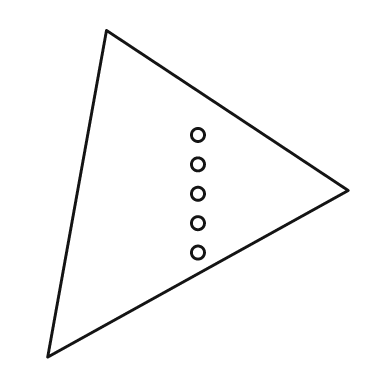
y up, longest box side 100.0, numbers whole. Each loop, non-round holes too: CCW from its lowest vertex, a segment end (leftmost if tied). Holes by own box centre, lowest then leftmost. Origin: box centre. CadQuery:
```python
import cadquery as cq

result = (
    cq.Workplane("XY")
    .moveTo(-46.0, -50.0)
    .lineTo(46.0, 1.0)
    .lineTo(-28.0, 50.0)
    .close()
    .moveTo(0.0, -18.0)
    .circle(2.0)
    .moveTo(0.0, -9.0)
    .circle(2.0)
    .moveTo(0.0, 0.0)
    .circle(2.0)
    .moveTo(0.0, 9.0)
    .circle(2.0)
    .moveTo(0.0, 18.0)
    .circle(2.0)
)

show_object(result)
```